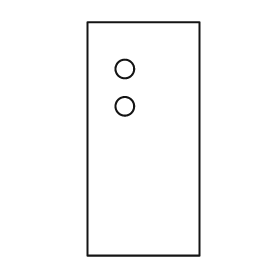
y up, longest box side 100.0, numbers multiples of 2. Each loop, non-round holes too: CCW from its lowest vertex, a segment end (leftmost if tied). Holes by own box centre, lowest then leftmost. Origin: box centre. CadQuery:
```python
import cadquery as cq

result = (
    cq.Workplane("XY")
    .moveTo(-24.0, -50.0)
    .lineTo(24.0, -50.0)
    .lineTo(24.0, 50.0)
    .lineTo(-24.0, 50.0)
    .close()
    .moveTo(-8.0, 14.0)
    .circle(4.0)
    .moveTo(-8.0, 30.0)
    .circle(4.0)
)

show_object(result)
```